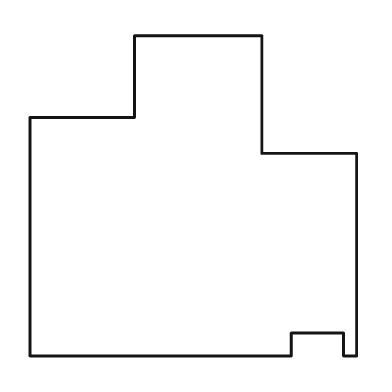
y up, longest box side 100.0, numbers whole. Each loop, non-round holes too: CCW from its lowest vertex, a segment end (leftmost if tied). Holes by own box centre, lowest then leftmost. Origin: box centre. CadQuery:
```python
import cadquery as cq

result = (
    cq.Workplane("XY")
    .moveTo(-50.0, -49.0)
    .lineTo(30.0, -49.0)
    .lineTo(30.0, -42.0)
    .lineTo(46.0, -42.0)
    .lineTo(46.0, -49.0)
    .lineTo(50.0, -49.0)
    .lineTo(50.0, 13.0)
    .lineTo(21.0, 13.0)
    .lineTo(21.0, 49.0)
    .lineTo(-18.0, 49.0)
    .lineTo(-18.0, 24.0)
    .lineTo(-50.0, 24.0)
    .close()
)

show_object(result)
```